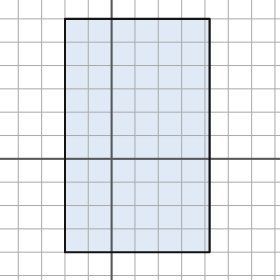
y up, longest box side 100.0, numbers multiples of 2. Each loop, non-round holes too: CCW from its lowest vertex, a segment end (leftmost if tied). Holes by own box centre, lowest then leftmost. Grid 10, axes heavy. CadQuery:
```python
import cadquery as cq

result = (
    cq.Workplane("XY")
    .moveTo(-20.0, -40.0)
    .lineTo(42.0, -40.0)
    .lineTo(42.0, 60.0)
    .lineTo(-20.0, 60.0)
    .close()
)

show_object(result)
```